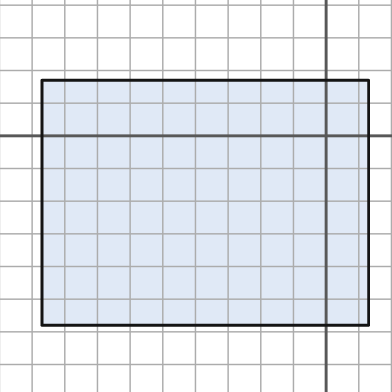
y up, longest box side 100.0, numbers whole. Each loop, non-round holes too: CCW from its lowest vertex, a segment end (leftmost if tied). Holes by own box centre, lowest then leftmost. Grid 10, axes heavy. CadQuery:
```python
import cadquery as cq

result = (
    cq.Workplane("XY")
    .moveTo(-87.0, -58.0)
    .lineTo(13.0, -58.0)
    .lineTo(13.0, 17.0)
    .lineTo(-87.0, 17.0)
    .close()
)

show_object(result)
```